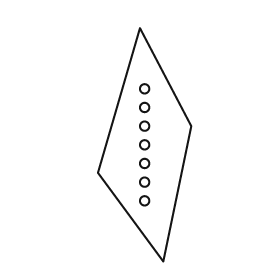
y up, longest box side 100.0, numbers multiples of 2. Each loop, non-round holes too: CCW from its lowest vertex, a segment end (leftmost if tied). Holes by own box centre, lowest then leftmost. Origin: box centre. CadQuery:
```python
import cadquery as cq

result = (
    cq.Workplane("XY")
    .moveTo(8.0, -50.0)
    .lineTo(20.0, 8.0)
    .lineTo(-2.0, 50.0)
    .lineTo(-20.0, -12.0)
    .close()
    .moveTo(0.0, -24.0)
    .circle(2.0)
    .moveTo(0.0, -16.0)
    .circle(2.0)
    .moveTo(0.0, -8.0)
    .circle(2.0)
    .moveTo(0.0, 0.0)
    .circle(2.0)
    .moveTo(0.0, 8.0)
    .circle(2.0)
    .moveTo(0.0, 16.0)
    .circle(2.0)
    .moveTo(0.0, 24.0)
    .circle(2.0)
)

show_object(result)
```